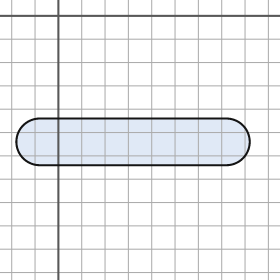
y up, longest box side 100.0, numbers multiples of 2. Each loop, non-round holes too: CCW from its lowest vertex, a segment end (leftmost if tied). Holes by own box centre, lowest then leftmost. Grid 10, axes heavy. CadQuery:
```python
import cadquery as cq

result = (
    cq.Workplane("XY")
    .moveTo(-8.0, -64.0)
    .lineTo(72.0, -64.0)
    .threePointArc((82.0, -54.0), (72.0, -44.0))
    .lineTo(-8.0, -44.0)
    .threePointArc((-18.0, -54.0), (-8.0, -64.0))
    .close()
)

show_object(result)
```